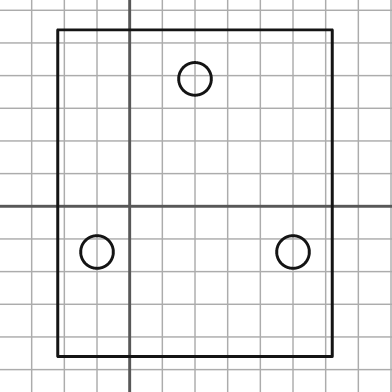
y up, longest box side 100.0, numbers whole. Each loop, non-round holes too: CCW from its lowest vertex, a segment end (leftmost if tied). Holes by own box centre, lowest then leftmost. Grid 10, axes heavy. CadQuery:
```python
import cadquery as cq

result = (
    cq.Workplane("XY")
    .moveTo(-22.0, -46.0)
    .lineTo(62.0, -46.0)
    .lineTo(62.0, 54.0)
    .lineTo(-22.0, 54.0)
    .close()
    .moveTo(-10.0, -14.0)
    .circle(5.0)
    .moveTo(50.0, -14.0)
    .circle(5.0)
    .moveTo(20.0, 39.0)
    .circle(5.0)
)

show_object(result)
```